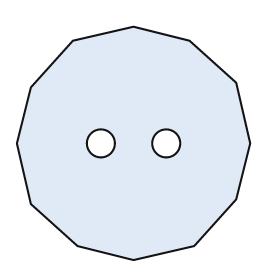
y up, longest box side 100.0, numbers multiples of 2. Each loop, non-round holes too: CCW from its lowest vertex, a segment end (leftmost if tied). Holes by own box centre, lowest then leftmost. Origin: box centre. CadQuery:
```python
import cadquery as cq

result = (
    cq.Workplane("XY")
    .moveTo(0.0, -50.0)
    .lineTo(26.0, -44.0)
    .lineTo(44.0, -24.0)
    .lineTo(50.0, 0.0)
    .lineTo(44.0, 26.0)
    .lineTo(24.0, 44.0)
    .lineTo(0.0, 50.0)
    .lineTo(-26.0, 44.0)
    .lineTo(-44.0, 24.0)
    .lineTo(-50.0, 0.0)
    .lineTo(-44.0, -26.0)
    .lineTo(-24.0, -44.0)
    .close()
    .moveTo(-14.0, 0.0)
    .circle(6.0)
    .moveTo(14.0, 0.0)
    .circle(6.0)
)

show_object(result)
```